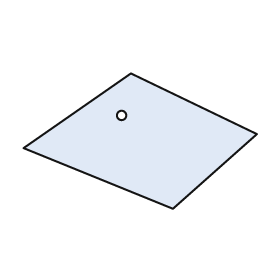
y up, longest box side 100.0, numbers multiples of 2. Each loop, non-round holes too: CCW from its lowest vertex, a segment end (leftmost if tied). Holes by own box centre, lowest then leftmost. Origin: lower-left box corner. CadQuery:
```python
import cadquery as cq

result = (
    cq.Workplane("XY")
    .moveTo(64.0, 0.0)
    .lineTo(100.0, 32.0)
    .lineTo(46.0, 58.0)
    .lineTo(0.0, 26.0)
    .close()
    .moveTo(42.0, 40.0)
    .circle(2.0)
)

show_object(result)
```